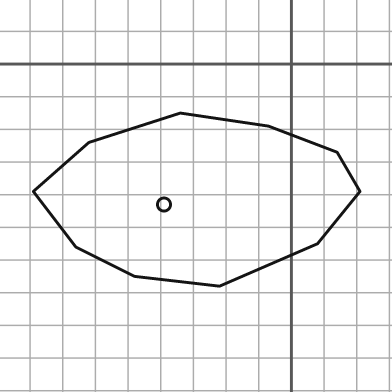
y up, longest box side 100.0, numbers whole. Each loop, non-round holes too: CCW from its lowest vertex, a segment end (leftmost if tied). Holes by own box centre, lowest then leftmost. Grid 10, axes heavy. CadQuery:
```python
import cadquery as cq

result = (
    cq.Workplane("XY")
    .moveTo(-22.0, -68.0)
    .lineTo(8.0, -55.0)
    .lineTo(21.0, -39.0)
    .lineTo(14.0, -27.0)
    .lineTo(-7.0, -19.0)
    .lineTo(-34.0, -15.0)
    .lineTo(-62.0, -24.0)
    .lineTo(-79.0, -39.0)
    .lineTo(-66.0, -56.0)
    .lineTo(-48.0, -65.0)
    .close()
    .moveTo(-39.0, -43.0)
    .circle(2.0)
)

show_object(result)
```